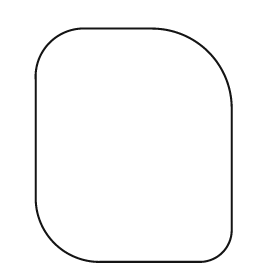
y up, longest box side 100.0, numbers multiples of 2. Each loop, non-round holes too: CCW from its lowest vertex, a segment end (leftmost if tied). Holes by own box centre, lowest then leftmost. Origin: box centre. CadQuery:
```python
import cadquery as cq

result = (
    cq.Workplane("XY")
    .moveTo(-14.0, -50.0)
    .lineTo(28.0, -50.0)
    .threePointArc((38.0, -46.0), (42.0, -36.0))
    .lineTo(42.0, 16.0)
    .threePointArc((32.0, 40.0), (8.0, 50.0))
    .lineTo(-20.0, 50.0)
    .threePointArc((-36.0, 44.0), (-42.0, 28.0))
    .lineTo(-42.0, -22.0)
    .threePointArc((-34.0, -42.0), (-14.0, -50.0))
    .close()
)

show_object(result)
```